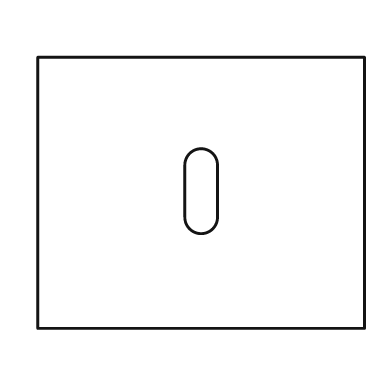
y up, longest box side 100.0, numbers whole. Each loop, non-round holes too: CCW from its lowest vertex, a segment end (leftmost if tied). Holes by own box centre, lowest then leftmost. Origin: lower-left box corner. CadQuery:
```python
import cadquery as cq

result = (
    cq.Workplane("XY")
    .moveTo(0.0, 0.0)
    .lineTo(100.0, 0.0)
    .lineTo(100.0, 83.0)
    .lineTo(0.0, 83.0)
    .close()
    .moveTo(45.0, 34.0)
    .threePointArc((50.0, 29.0), (55.0, 34.0))
    .lineTo(55.0, 50.0)
    .threePointArc((50.0, 55.0), (45.0, 50.0))
    .close()
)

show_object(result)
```